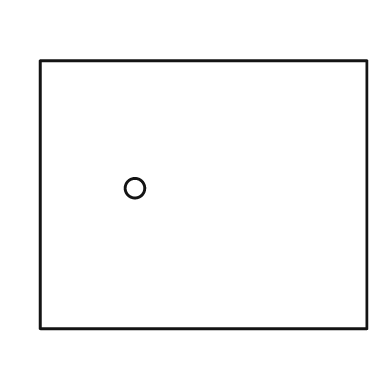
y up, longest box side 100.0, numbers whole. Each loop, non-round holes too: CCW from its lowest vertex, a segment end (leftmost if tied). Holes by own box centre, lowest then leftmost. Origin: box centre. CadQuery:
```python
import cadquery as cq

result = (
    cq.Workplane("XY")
    .moveTo(-50.0, -41.0)
    .lineTo(50.0, -41.0)
    .lineTo(50.0, 41.0)
    .lineTo(-50.0, 41.0)
    .close()
    .moveTo(-21.0, 2.0)
    .circle(3.0)
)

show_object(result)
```